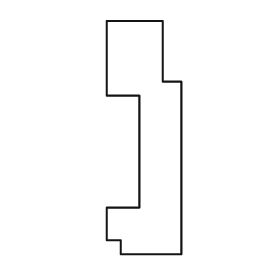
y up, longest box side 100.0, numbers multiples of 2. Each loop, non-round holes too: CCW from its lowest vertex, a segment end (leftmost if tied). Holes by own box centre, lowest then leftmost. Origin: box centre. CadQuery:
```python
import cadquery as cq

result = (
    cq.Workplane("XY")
    .moveTo(-10.0, -50.0)
    .lineTo(16.0, -50.0)
    .lineTo(16.0, 24.0)
    .lineTo(8.0, 24.0)
    .lineTo(8.0, 50.0)
    .lineTo(-16.0, 50.0)
    .lineTo(-16.0, 18.0)
    .lineTo(-2.0, 18.0)
    .lineTo(-2.0, -30.0)
    .lineTo(-16.0, -30.0)
    .lineTo(-16.0, -44.0)
    .lineTo(-10.0, -44.0)
    .close()
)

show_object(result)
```